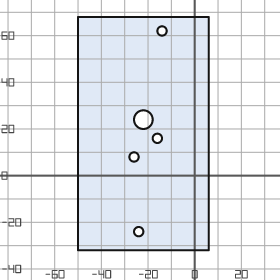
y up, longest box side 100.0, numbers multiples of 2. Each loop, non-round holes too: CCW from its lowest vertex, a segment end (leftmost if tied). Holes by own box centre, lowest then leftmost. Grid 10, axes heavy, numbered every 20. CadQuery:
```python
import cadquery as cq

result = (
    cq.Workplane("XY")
    .moveTo(-50.0, -32.0)
    .lineTo(6.0, -32.0)
    .lineTo(6.0, 68.0)
    .lineTo(-50.0, 68.0)
    .close()
    .moveTo(-24.0, -24.0)
    .circle(2.0)
    .moveTo(-26.0, 8.0)
    .circle(2.0)
    .moveTo(-16.0, 16.0)
    .circle(2.0)
    .moveTo(-22.0, 24.0)
    .circle(4.0)
    .moveTo(-14.0, 62.0)
    .circle(2.0)
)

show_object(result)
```